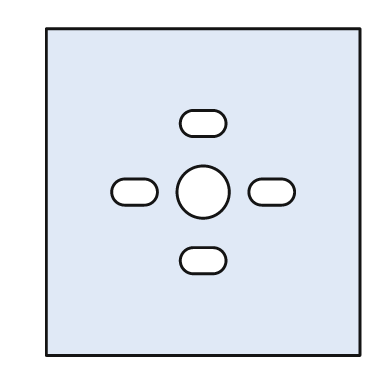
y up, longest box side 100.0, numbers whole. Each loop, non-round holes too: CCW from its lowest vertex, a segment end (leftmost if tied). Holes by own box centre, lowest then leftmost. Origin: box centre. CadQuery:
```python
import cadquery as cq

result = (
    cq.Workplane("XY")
    .moveTo(-48.0, -50.0)
    .lineTo(48.0, -50.0)
    .lineTo(48.0, 50.0)
    .lineTo(-48.0, 50.0)
    .close()
    .moveTo(-3.0, -25.0)
    .lineTo(3.0, -25.0)
    .threePointArc((7.0, -21.0), (3.0, -17.0))
    .lineTo(-3.0, -17.0)
    .threePointArc((-7.0, -21.0), (-3.0, -25.0))
    .close()
    .moveTo(-24.0, -4.0)
    .lineTo(-18.0, -4.0)
    .threePointArc((-14.0, 0.0), (-18.0, 4.0))
    .lineTo(-24.0, 4.0)
    .threePointArc((-28.0, 0.0), (-24.0, -4.0))
    .close()
    .moveTo(0.0, 0.0)
    .circle(8.0)
    .moveTo(18.0, -4.0)
    .lineTo(24.0, -4.0)
    .threePointArc((28.0, 0.0), (24.0, 4.0))
    .lineTo(18.0, 4.0)
    .threePointArc((14.0, 0.0), (18.0, -4.0))
    .close()
    .moveTo(-3.0, 17.0)
    .lineTo(3.0, 17.0)
    .threePointArc((7.0, 21.0), (3.0, 25.0))
    .lineTo(-3.0, 25.0)
    .threePointArc((-7.0, 21.0), (-3.0, 17.0))
    .close()
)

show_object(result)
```